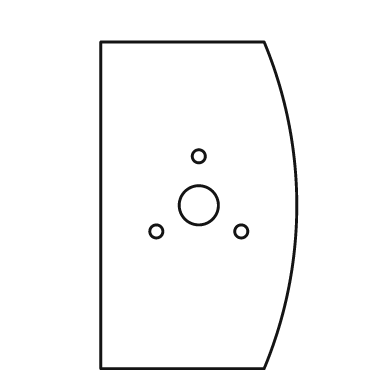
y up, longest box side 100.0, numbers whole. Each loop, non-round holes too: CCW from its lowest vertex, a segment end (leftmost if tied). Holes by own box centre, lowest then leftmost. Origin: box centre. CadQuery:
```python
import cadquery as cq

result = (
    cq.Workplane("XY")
    .moveTo(-30.0, -50.0)
    .lineTo(20.0, -50.0)
    .threePointArc((30.0, 0.0), (20.0, 50.0))
    .lineTo(-30.0, 50.0)
    .close()
    .moveTo(-13.0, -8.0)
    .circle(2.0)
    .moveTo(13.0, -8.0)
    .circle(2.0)
    .moveTo(0.0, 0.0)
    .circle(6.0)
    .moveTo(0.0, 15.0)
    .circle(2.0)
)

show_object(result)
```